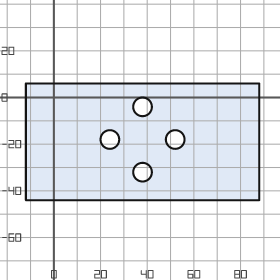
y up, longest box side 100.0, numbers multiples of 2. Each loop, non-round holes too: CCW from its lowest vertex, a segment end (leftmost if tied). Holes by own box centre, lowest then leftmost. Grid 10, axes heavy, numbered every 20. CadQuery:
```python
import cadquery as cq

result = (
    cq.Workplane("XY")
    .moveTo(-12.0, -44.0)
    .lineTo(88.0, -44.0)
    .lineTo(88.0, 6.0)
    .lineTo(-12.0, 6.0)
    .close()
    .moveTo(38.0, -32.0)
    .circle(4.0)
    .moveTo(24.0, -18.0)
    .circle(4.0)
    .moveTo(52.0, -18.0)
    .circle(4.0)
    .moveTo(38.0, -4.0)
    .circle(4.0)
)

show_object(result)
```